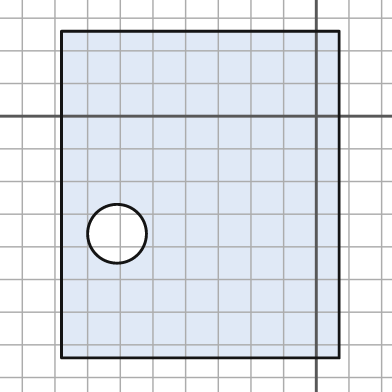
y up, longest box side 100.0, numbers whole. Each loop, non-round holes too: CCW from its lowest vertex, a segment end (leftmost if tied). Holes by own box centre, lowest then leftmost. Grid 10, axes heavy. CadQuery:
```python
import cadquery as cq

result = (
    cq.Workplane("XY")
    .moveTo(-78.0, -74.0)
    .lineTo(7.0, -74.0)
    .lineTo(7.0, 26.0)
    .lineTo(-78.0, 26.0)
    .close()
    .moveTo(-61.0, -36.0)
    .circle(9.0)
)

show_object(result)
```